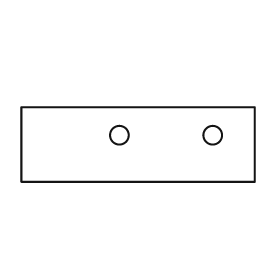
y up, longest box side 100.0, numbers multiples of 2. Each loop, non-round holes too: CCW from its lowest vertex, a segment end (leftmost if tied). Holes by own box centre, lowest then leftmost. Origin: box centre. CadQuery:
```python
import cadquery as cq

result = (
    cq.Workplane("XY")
    .moveTo(-50.0, -16.0)
    .lineTo(50.0, -16.0)
    .lineTo(50.0, 16.0)
    .lineTo(-50.0, 16.0)
    .close()
    .moveTo(-8.0, 4.0)
    .circle(4.0)
    .moveTo(32.0, 4.0)
    .circle(4.0)
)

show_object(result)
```